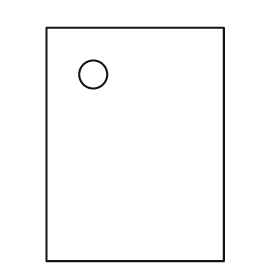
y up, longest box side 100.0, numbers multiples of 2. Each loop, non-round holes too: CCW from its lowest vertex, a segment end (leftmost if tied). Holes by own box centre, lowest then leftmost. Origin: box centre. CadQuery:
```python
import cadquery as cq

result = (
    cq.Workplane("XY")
    .moveTo(-38.0, -50.0)
    .lineTo(38.0, -50.0)
    .lineTo(38.0, 50.0)
    .lineTo(-38.0, 50.0)
    .close()
    .moveTo(-18.0, 30.0)
    .circle(6.0)
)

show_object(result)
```